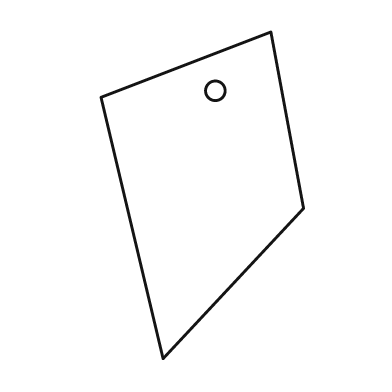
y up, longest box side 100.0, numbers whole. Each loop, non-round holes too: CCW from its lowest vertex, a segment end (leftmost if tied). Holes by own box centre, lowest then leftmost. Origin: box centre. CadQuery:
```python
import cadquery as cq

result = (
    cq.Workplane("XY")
    .moveTo(-12.0, -50.0)
    .lineTo(31.0, -4.0)
    .lineTo(21.0, 50.0)
    .lineTo(-31.0, 30.0)
    .close()
    .moveTo(4.0, 32.0)
    .circle(3.0)
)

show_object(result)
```